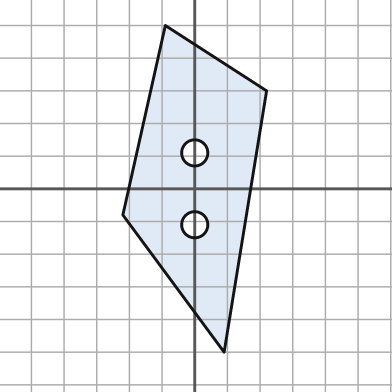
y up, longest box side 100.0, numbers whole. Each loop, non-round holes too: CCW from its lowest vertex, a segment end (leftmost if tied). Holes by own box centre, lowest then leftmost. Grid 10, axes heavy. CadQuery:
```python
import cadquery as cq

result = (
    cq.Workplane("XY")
    .moveTo(9.0, -50.0)
    .lineTo(22.0, 30.0)
    .lineTo(-9.0, 50.0)
    .lineTo(-22.0, -8.0)
    .close()
    .moveTo(0.0, -11.0)
    .circle(4.0)
    .moveTo(0.0, 11.0)
    .circle(4.0)
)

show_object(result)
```